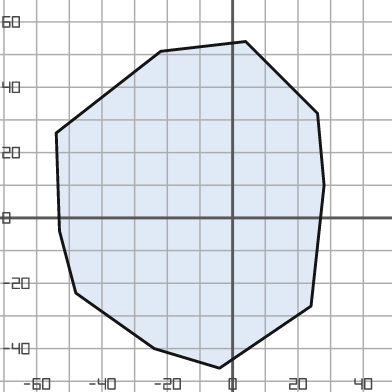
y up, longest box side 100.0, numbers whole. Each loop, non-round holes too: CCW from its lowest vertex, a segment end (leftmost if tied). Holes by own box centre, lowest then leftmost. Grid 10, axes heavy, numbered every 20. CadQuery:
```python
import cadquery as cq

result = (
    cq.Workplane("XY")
    .moveTo(-4.0, -46.0)
    .lineTo(24.0, -27.0)
    .lineTo(28.0, 10.0)
    .lineTo(26.0, 32.0)
    .lineTo(4.0, 54.0)
    .lineTo(-22.0, 51.0)
    .lineTo(-54.0, 26.0)
    .lineTo(-53.0, -4.0)
    .lineTo(-48.0, -23.0)
    .lineTo(-24.0, -40.0)
    .close()
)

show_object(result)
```